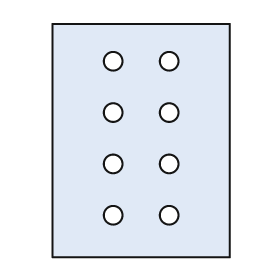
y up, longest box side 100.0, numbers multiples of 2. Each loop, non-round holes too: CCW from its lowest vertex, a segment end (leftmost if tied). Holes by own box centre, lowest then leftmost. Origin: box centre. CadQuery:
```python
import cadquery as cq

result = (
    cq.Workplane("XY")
    .moveTo(-38.0, -50.0)
    .lineTo(38.0, -50.0)
    .lineTo(38.0, 50.0)
    .lineTo(-38.0, 50.0)
    .close()
    .moveTo(-12.0, -32.0)
    .circle(4.0)
    .moveTo(12.0, -32.0)
    .circle(4.0)
    .moveTo(-12.0, -10.0)
    .circle(4.0)
    .moveTo(12.0, -10.0)
    .circle(4.0)
    .moveTo(-12.0, 12.0)
    .circle(4.0)
    .moveTo(12.0, 12.0)
    .circle(4.0)
    .moveTo(-12.0, 34.0)
    .circle(4.0)
    .moveTo(12.0, 34.0)
    .circle(4.0)
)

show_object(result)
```